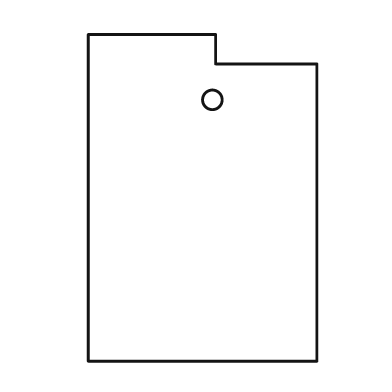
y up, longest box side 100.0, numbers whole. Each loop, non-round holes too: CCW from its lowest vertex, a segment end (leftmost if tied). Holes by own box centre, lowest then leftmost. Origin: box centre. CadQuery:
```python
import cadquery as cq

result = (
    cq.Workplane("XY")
    .moveTo(-35.0, -50.0)
    .lineTo(35.0, -50.0)
    .lineTo(35.0, 41.0)
    .lineTo(4.0, 41.0)
    .lineTo(4.0, 50.0)
    .lineTo(-35.0, 50.0)
    .close()
    .moveTo(3.0, 30.0)
    .circle(3.0)
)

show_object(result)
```